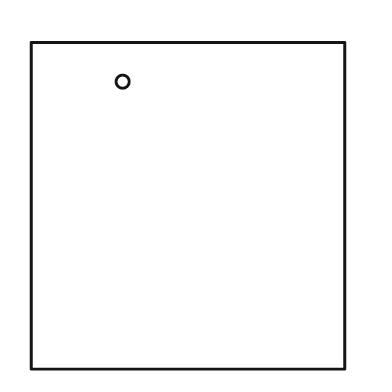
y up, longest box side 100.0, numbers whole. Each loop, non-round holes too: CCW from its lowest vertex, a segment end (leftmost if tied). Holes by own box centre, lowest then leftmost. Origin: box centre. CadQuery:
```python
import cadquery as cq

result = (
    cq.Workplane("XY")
    .moveTo(-48.0, -50.0)
    .lineTo(48.0, -50.0)
    .lineTo(48.0, 50.0)
    .lineTo(-48.0, 50.0)
    .close()
    .moveTo(-20.0, 38.0)
    .circle(2.0)
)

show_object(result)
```